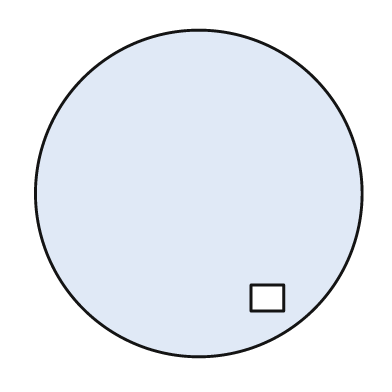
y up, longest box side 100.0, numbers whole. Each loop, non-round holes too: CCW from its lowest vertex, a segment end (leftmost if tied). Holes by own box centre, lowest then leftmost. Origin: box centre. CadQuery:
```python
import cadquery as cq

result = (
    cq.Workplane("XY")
    .moveTo(0.0, 0.0)
    .circle(50.0)
    .moveTo(16.0, -36.0)
    .lineTo(26.0, -36.0)
    .lineTo(26.0, -28.0)
    .lineTo(16.0, -28.0)
    .close()
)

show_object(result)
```